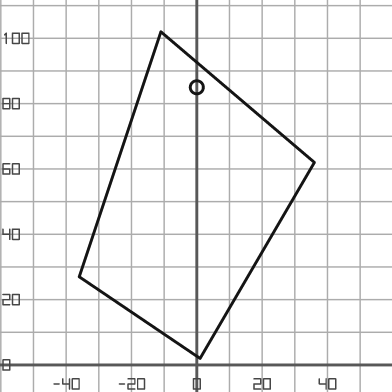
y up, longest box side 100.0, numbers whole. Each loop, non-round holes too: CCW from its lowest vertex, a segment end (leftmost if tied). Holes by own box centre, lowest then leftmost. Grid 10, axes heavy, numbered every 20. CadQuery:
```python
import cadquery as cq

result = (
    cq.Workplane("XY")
    .moveTo(1.0, 2.0)
    .lineTo(36.0, 62.0)
    .lineTo(-11.0, 102.0)
    .lineTo(-36.0, 27.0)
    .close()
    .moveTo(0.0, 85.0)
    .circle(2.0)
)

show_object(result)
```